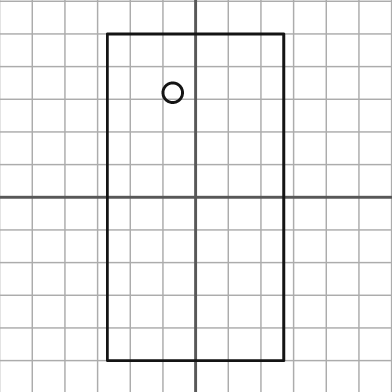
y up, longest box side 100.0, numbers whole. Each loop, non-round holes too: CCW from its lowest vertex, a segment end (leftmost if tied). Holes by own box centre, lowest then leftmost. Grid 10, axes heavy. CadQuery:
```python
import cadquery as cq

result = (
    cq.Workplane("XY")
    .moveTo(-27.0, -50.0)
    .lineTo(27.0, -50.0)
    .lineTo(27.0, 50.0)
    .lineTo(-27.0, 50.0)
    .close()
    .moveTo(-7.0, 32.0)
    .circle(3.0)
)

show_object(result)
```